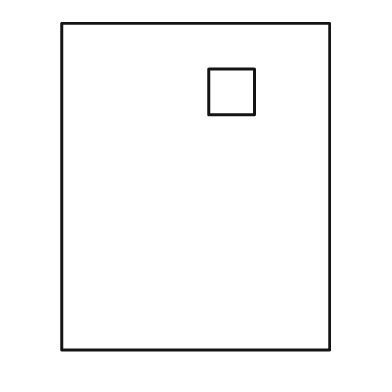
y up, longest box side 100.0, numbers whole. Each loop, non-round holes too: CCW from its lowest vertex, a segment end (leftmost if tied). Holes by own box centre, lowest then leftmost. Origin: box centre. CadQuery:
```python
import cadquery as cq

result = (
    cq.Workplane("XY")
    .moveTo(-41.0, -50.0)
    .lineTo(41.0, -50.0)
    .lineTo(41.0, 50.0)
    .lineTo(-41.0, 50.0)
    .close()
    .moveTo(4.0, 22.0)
    .lineTo(18.0, 22.0)
    .lineTo(18.0, 36.0)
    .lineTo(4.0, 36.0)
    .close()
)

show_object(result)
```